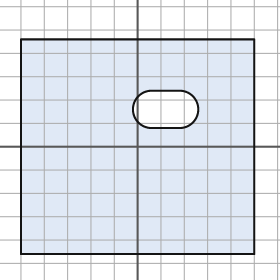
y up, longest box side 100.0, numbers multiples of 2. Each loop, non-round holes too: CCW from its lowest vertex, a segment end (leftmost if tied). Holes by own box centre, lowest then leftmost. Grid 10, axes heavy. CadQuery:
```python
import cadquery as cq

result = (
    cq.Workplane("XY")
    .moveTo(-50.0, -46.0)
    .lineTo(50.0, -46.0)
    .lineTo(50.0, 46.0)
    .lineTo(-50.0, 46.0)
    .close()
    .moveTo(6.0, 8.0)
    .lineTo(18.0, 8.0)
    .threePointArc((26.0, 16.0), (18.0, 24.0))
    .lineTo(6.0, 24.0)
    .threePointArc((-2.0, 16.0), (6.0, 8.0))
    .close()
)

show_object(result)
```